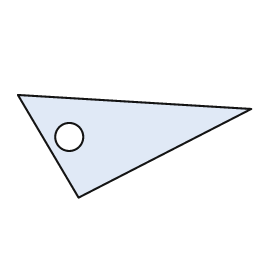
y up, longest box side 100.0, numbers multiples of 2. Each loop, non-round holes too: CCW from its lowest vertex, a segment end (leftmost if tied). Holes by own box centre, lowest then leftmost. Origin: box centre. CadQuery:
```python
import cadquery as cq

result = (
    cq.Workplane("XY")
    .moveTo(-24.0, -22.0)
    .lineTo(50.0, 16.0)
    .lineTo(-50.0, 22.0)
    .close()
    .moveTo(-28.0, 4.0)
    .circle(6.0)
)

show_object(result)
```